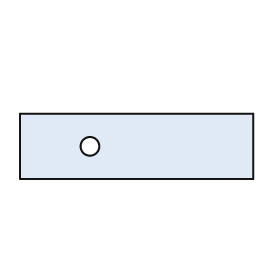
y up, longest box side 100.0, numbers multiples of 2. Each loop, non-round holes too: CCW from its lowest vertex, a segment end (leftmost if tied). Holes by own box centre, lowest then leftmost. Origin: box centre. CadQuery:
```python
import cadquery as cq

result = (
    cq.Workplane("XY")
    .moveTo(-50.0, -14.0)
    .lineTo(50.0, -14.0)
    .lineTo(50.0, 14.0)
    .lineTo(-50.0, 14.0)
    .close()
    .moveTo(-20.0, 0.0)
    .circle(4.0)
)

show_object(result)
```